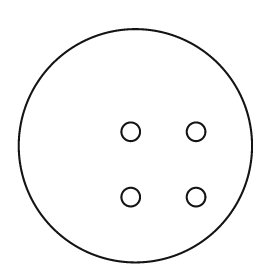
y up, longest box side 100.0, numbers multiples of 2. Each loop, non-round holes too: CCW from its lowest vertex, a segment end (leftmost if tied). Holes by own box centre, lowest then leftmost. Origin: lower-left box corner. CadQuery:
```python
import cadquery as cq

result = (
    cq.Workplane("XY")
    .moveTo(50.0, 50.0)
    .circle(50.0)
    .moveTo(48.0, 28.0)
    .circle(4.0)
    .moveTo(76.0, 28.0)
    .circle(4.0)
    .moveTo(48.0, 56.0)
    .circle(4.0)
    .moveTo(76.0, 56.0)
    .circle(4.0)
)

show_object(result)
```